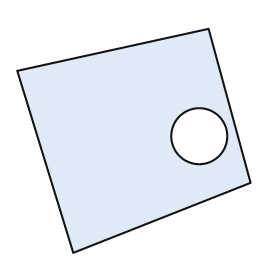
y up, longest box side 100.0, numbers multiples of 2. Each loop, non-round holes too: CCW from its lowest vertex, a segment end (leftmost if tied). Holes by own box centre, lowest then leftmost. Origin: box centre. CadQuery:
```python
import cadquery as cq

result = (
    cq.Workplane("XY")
    .moveTo(-26.0, -48.0)
    .lineTo(50.0, -18.0)
    .lineTo(32.0, 48.0)
    .lineTo(-50.0, 30.0)
    .close()
    .moveTo(28.0, 2.0)
    .circle(12.0)
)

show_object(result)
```